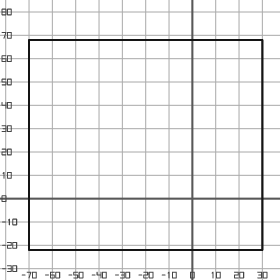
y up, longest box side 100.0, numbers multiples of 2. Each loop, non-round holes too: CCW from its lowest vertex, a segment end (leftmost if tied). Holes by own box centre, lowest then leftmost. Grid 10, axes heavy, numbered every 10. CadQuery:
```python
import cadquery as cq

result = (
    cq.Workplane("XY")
    .moveTo(-70.0, -22.0)
    .lineTo(30.0, -22.0)
    .lineTo(30.0, 68.0)
    .lineTo(-70.0, 68.0)
    .close()
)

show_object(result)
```